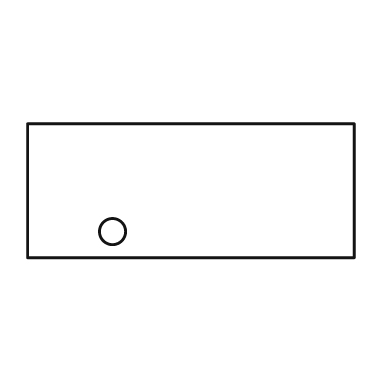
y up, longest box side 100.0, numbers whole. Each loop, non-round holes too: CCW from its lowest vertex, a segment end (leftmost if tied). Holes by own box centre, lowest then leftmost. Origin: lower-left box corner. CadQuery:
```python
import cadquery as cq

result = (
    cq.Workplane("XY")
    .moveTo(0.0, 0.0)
    .lineTo(100.0, 0.0)
    .lineTo(100.0, 41.0)
    .lineTo(0.0, 41.0)
    .close()
    .moveTo(26.0, 8.0)
    .circle(4.0)
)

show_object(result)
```